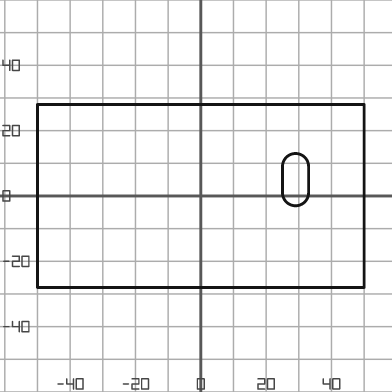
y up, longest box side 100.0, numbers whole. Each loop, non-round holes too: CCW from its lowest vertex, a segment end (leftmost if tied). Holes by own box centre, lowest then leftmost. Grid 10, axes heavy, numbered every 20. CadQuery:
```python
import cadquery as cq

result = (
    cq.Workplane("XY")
    .moveTo(-50.0, -28.0)
    .lineTo(50.0, -28.0)
    .lineTo(50.0, 28.0)
    .lineTo(-50.0, 28.0)
    .close()
    .moveTo(25.0, 1.0)
    .threePointArc((29.0, -3.0), (33.0, 1.0))
    .lineTo(33.0, 9.0)
    .threePointArc((29.0, 13.0), (25.0, 9.0))
    .close()
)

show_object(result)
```